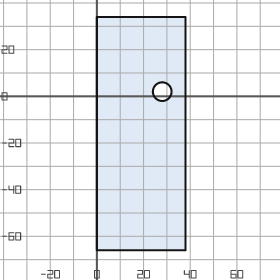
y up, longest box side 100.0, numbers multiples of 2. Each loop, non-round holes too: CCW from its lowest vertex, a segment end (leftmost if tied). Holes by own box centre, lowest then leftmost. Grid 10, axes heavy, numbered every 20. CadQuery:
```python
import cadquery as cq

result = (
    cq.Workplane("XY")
    .moveTo(0.0, -66.0)
    .lineTo(38.0, -66.0)
    .lineTo(38.0, 34.0)
    .lineTo(0.0, 34.0)
    .close()
    .moveTo(28.0, 2.0)
    .circle(4.0)
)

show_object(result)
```